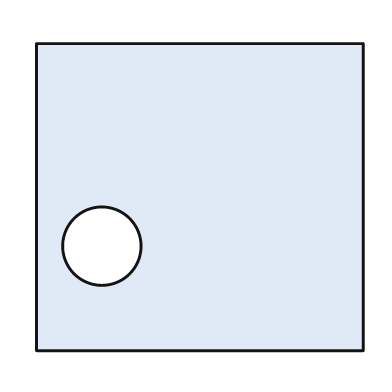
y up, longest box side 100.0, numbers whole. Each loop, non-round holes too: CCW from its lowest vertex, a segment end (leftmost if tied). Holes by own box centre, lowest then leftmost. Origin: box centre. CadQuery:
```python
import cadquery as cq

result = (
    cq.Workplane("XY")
    .moveTo(-50.0, -47.0)
    .lineTo(50.0, -47.0)
    .lineTo(50.0, 47.0)
    .lineTo(-50.0, 47.0)
    .close()
    .moveTo(-30.0, -15.0)
    .circle(12.0)
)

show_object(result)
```